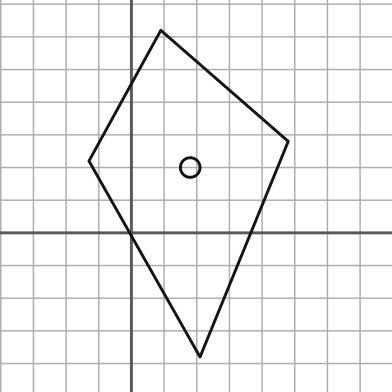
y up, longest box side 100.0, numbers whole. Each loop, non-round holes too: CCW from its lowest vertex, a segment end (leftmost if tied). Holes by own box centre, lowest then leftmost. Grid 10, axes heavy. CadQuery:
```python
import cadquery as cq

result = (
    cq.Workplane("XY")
    .moveTo(21.0, -38.0)
    .lineTo(48.0, 28.0)
    .lineTo(9.0, 62.0)
    .lineTo(-13.0, 22.0)
    .close()
    .moveTo(18.0, 20.0)
    .circle(3.0)
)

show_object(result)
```